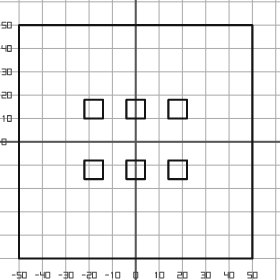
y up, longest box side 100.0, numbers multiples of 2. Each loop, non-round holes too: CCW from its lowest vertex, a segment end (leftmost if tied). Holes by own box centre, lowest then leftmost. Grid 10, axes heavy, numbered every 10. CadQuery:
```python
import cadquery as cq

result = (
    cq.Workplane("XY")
    .moveTo(-50.0, -50.0)
    .lineTo(50.0, -50.0)
    .lineTo(50.0, 50.0)
    .lineTo(-50.0, 50.0)
    .close()
    .moveTo(-22.0, -16.0)
    .lineTo(-14.0, -16.0)
    .lineTo(-14.0, -8.0)
    .lineTo(-22.0, -8.0)
    .close()
    .moveTo(-4.0, -16.0)
    .lineTo(4.0, -16.0)
    .lineTo(4.0, -8.0)
    .lineTo(-4.0, -8.0)
    .close()
    .moveTo(14.0, -16.0)
    .lineTo(22.0, -16.0)
    .lineTo(22.0, -8.0)
    .lineTo(14.0, -8.0)
    .close()
    .moveTo(-22.0, 10.0)
    .lineTo(-14.0, 10.0)
    .lineTo(-14.0, 18.0)
    .lineTo(-22.0, 18.0)
    .close()
    .moveTo(-4.0, 10.0)
    .lineTo(4.0, 10.0)
    .lineTo(4.0, 18.0)
    .lineTo(-4.0, 18.0)
    .close()
    .moveTo(14.0, 10.0)
    .lineTo(22.0, 10.0)
    .lineTo(22.0, 18.0)
    .lineTo(14.0, 18.0)
    .close()
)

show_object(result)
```